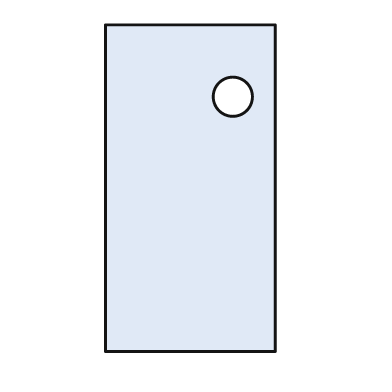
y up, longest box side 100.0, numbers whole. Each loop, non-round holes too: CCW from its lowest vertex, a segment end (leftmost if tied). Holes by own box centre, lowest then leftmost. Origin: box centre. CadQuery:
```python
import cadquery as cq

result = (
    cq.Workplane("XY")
    .moveTo(-26.0, -50.0)
    .lineTo(26.0, -50.0)
    .lineTo(26.0, 50.0)
    .lineTo(-26.0, 50.0)
    .close()
    .moveTo(13.0, 28.0)
    .circle(6.0)
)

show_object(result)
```